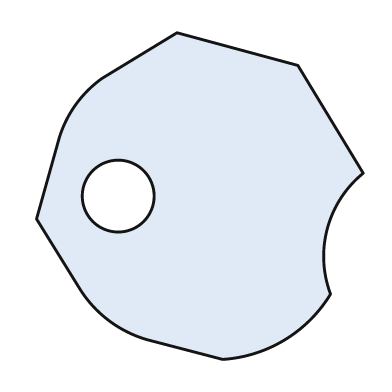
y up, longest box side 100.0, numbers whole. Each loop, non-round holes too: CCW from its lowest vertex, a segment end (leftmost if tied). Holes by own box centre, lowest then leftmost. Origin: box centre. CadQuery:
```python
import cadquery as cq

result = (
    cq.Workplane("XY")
    .moveTo(7.0, -50.0)
    .threePointArc((26.0, -44.0), (40.0, -30.0))
    .threePointArc((39.0, -10.0), (50.0, 7.0))
    .lineTo(30.0, 40.0)
    .lineTo(-7.0, 50.0)
    .lineTo(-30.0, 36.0)
    .threePointArc((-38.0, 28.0), (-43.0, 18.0))
    .lineTo(-50.0, -7.0)
    .lineTo(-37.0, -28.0)
    .threePointArc((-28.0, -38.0), (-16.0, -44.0))
    .close()
    .moveTo(-25.0, 0.0)
    .circle(11.0)
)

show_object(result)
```